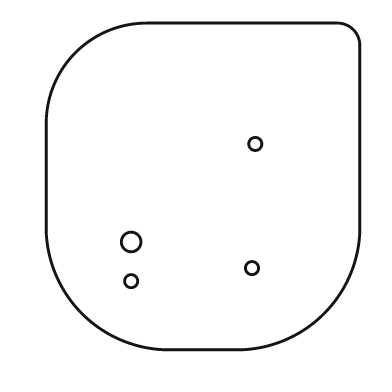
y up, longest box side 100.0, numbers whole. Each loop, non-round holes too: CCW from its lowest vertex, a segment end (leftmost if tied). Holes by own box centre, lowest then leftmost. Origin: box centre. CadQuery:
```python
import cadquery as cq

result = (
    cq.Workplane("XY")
    .moveTo(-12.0, -50.0)
    .lineTo(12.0, -50.0)
    .threePointArc((37.0, -39.0), (48.0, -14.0))
    .lineTo(48.0, 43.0)
    .threePointArc((46.0, 48.0), (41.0, 50.0))
    .lineTo(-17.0, 50.0)
    .threePointArc((-39.0, 41.0), (-48.0, 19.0))
    .lineTo(-48.0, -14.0)
    .threePointArc((-37.0, -39.0), (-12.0, -50.0))
    .close()
    .moveTo(-22.0, -29.0)
    .circle(2.0)
    .moveTo(15.0, -25.0)
    .circle(2.0)
    .moveTo(-22.0, -17.0)
    .circle(3.0)
    .moveTo(16.0, 13.0)
    .circle(2.0)
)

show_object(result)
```